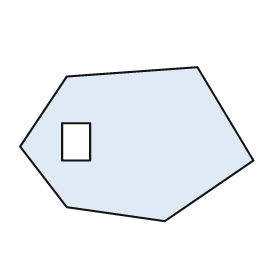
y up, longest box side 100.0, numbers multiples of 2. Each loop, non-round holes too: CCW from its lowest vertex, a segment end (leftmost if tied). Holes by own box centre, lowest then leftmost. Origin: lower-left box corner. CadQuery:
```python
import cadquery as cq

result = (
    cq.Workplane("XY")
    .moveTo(62.0, 0.0)
    .lineTo(100.0, 26.0)
    .lineTo(76.0, 66.0)
    .lineTo(20.0, 62.0)
    .lineTo(0.0, 32.0)
    .lineTo(20.0, 6.0)
    .close()
    .moveTo(18.0, 26.0)
    .lineTo(30.0, 26.0)
    .lineTo(30.0, 42.0)
    .lineTo(18.0, 42.0)
    .close()
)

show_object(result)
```